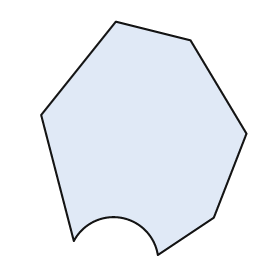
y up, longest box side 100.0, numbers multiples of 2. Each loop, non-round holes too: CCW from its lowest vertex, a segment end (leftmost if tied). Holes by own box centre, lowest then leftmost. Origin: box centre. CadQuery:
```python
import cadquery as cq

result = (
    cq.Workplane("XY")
    .moveTo(6.0, -50.0)
    .lineTo(30.0, -34.0)
    .lineTo(44.0, 2.0)
    .lineTo(20.0, 42.0)
    .lineTo(-12.0, 50.0)
    .lineTo(-44.0, 10.0)
    .lineTo(-30.0, -44.0)
    .threePointArc((-10.0, -34.0), (6.0, -50.0))
    .close()
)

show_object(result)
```